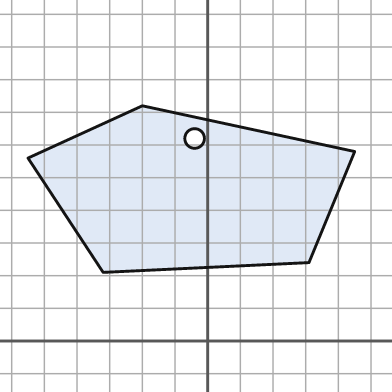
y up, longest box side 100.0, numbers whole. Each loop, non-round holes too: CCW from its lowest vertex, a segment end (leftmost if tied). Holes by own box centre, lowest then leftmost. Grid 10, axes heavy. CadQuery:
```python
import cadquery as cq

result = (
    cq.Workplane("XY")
    .moveTo(-32.0, 21.0)
    .lineTo(31.0, 24.0)
    .lineTo(45.0, 58.0)
    .lineTo(-20.0, 72.0)
    .lineTo(-55.0, 56.0)
    .close()
    .moveTo(-4.0, 62.0)
    .circle(3.0)
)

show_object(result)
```